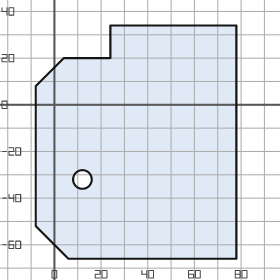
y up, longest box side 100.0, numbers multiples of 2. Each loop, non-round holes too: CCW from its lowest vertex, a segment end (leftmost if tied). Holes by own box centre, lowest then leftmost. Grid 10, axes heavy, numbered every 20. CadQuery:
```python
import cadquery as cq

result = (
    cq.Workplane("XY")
    .moveTo(6.0, -66.0)
    .lineTo(78.0, -66.0)
    .lineTo(78.0, 34.0)
    .lineTo(24.0, 34.0)
    .lineTo(24.0, 20.0)
    .lineTo(4.0, 20.0)
    .lineTo(-8.0, 8.0)
    .lineTo(-8.0, -52.0)
    .close()
    .moveTo(12.0, -32.0)
    .circle(4.0)
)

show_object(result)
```